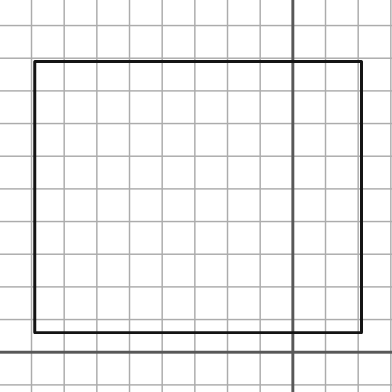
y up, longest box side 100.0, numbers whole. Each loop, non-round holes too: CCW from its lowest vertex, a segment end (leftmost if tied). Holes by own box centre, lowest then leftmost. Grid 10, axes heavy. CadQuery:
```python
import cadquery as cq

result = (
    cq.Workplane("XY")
    .moveTo(-79.0, 6.0)
    .lineTo(21.0, 6.0)
    .lineTo(21.0, 89.0)
    .lineTo(-79.0, 89.0)
    .close()
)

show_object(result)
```